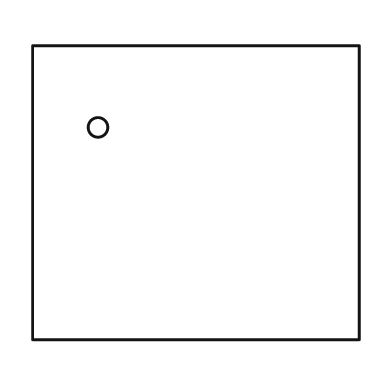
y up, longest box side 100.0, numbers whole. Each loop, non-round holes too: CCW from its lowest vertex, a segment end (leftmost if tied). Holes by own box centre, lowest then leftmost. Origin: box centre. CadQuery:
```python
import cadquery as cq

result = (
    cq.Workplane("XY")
    .moveTo(-50.0, -45.0)
    .lineTo(50.0, -45.0)
    .lineTo(50.0, 45.0)
    .lineTo(-50.0, 45.0)
    .close()
    .moveTo(-30.0, 20.0)
    .circle(3.0)
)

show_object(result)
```